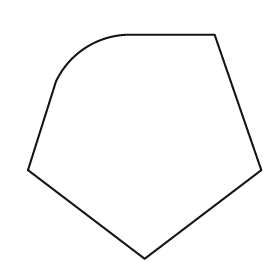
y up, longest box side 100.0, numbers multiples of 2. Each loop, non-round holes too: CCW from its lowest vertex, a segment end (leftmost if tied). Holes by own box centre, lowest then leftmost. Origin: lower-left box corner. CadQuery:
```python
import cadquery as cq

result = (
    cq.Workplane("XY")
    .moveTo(50.0, 0.0)
    .lineTo(100.0, 38.0)
    .lineTo(80.0, 96.0)
    .lineTo(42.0, 96.0)
    .threePointArc((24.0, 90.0), (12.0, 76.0))
    .lineTo(0.0, 38.0)
    .close()
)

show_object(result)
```